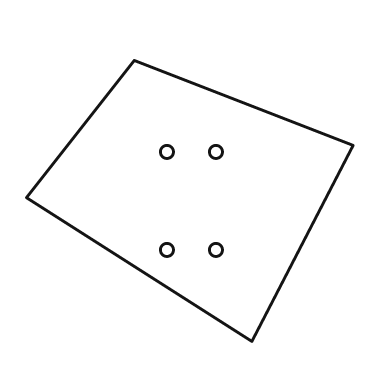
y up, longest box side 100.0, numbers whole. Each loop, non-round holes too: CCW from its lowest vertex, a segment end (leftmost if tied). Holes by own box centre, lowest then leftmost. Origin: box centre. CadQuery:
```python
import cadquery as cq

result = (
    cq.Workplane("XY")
    .moveTo(19.0, -43.0)
    .lineTo(50.0, 17.0)
    .lineTo(-17.0, 43.0)
    .lineTo(-50.0, 1.0)
    .close()
    .moveTo(-7.0, -15.0)
    .circle(2.0)
    .moveTo(8.0, -15.0)
    .circle(2.0)
    .moveTo(-7.0, 15.0)
    .circle(2.0)
    .moveTo(8.0, 15.0)
    .circle(2.0)
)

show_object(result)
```